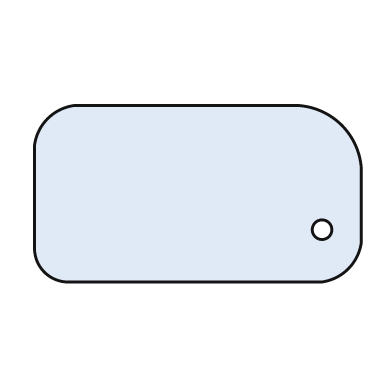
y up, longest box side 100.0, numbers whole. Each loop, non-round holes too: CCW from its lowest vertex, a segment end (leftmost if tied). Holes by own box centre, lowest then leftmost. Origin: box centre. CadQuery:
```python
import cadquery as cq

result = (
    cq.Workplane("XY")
    .moveTo(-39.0, -27.0)
    .lineTo(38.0, -27.0)
    .threePointArc((46.0, -23.0), (50.0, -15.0))
    .lineTo(50.0, 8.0)
    .threePointArc((44.0, 21.0), (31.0, 27.0))
    .lineTo(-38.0, 27.0)
    .threePointArc((-46.0, 23.0), (-50.0, 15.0))
    .lineTo(-50.0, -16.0)
    .threePointArc((-47.0, -24.0), (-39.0, -27.0))
    .close()
    .moveTo(38.0, -11.0)
    .circle(3.0)
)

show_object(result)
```